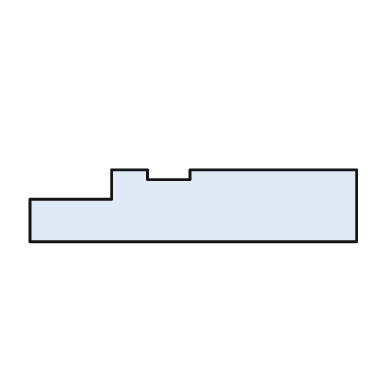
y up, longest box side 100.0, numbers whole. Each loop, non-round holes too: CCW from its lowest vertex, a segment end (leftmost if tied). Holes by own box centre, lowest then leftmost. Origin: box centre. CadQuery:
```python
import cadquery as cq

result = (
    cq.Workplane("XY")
    .moveTo(-50.0, -11.0)
    .lineTo(50.0, -11.0)
    .lineTo(50.0, 11.0)
    .lineTo(-1.0, 11.0)
    .lineTo(-1.0, 8.0)
    .lineTo(-14.0, 8.0)
    .lineTo(-14.0, 11.0)
    .lineTo(-25.0, 11.0)
    .lineTo(-25.0, 2.0)
    .lineTo(-50.0, 2.0)
    .close()
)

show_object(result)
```